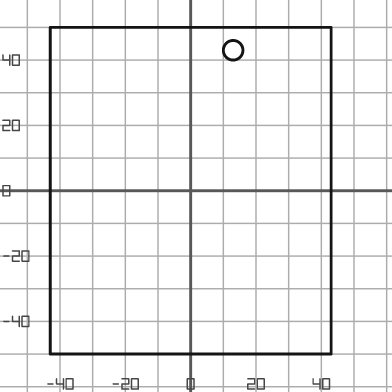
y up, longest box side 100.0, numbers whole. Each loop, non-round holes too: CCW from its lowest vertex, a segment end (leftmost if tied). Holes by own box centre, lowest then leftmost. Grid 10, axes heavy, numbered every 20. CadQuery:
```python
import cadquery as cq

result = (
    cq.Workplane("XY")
    .moveTo(-43.0, -50.0)
    .lineTo(43.0, -50.0)
    .lineTo(43.0, 50.0)
    .lineTo(-43.0, 50.0)
    .close()
    .moveTo(13.0, 43.0)
    .circle(3.0)
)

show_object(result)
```